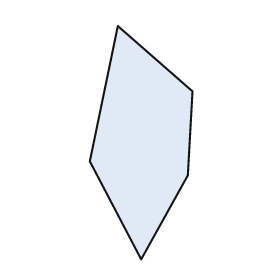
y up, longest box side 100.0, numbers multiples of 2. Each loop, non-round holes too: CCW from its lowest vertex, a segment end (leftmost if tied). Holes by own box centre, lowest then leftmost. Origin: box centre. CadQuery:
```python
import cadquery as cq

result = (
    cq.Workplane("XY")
    .moveTo(0.0, -50.0)
    .lineTo(20.0, -14.0)
    .lineTo(22.0, 22.0)
    .lineTo(-10.0, 50.0)
    .lineTo(-22.0, -8.0)
    .close()
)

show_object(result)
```